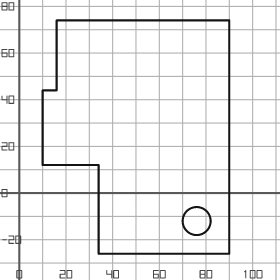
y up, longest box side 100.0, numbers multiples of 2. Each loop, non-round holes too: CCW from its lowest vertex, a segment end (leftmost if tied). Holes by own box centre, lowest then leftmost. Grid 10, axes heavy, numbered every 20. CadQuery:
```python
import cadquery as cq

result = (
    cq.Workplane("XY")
    .moveTo(34.0, -26.0)
    .lineTo(90.0, -26.0)
    .lineTo(90.0, 74.0)
    .lineTo(16.0, 74.0)
    .lineTo(16.0, 44.0)
    .lineTo(10.0, 44.0)
    .lineTo(10.0, 12.0)
    .lineTo(34.0, 12.0)
    .close()
    .moveTo(76.0, -12.0)
    .circle(6.0)
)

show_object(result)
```